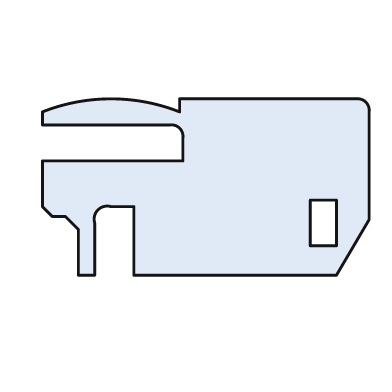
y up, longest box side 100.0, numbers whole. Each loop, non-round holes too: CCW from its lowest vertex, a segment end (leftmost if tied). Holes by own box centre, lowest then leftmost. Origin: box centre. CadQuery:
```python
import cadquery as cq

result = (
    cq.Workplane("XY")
    .moveTo(-39.0, -27.0)
    .lineTo(-34.0, -27.0)
    .lineTo(-34.0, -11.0)
    .threePointArc((-33.0, -7.0), (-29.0, -6.0))
    .lineTo(-22.0, -6.0)
    .lineTo(-22.0, -27.0)
    .lineTo(40.0, -27.0)
    .lineTo(50.0, -10.0)
    .lineTo(50.0, 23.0)
    .threePointArc((49.0, 26.0), (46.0, 27.0))
    .lineTo(-8.0, 27.0)
    .lineTo(-8.0, 23.0)
    .threePointArc((-29.0, 27.0), (-50.0, 23.0))
    .lineTo(-50.0, 19.0)
    .lineTo(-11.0, 19.0)
    .threePointArc((-8.0, 18.0), (-7.0, 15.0))
    .lineTo(-7.0, 8.0)
    .lineTo(-50.0, 8.0)
    .lineTo(-50.0, -6.0)
    .lineTo(-47.0, -9.0)
    .lineTo(-43.0, -9.0)
    .lineTo(-39.0, -13.0)
    .close()
    .moveTo(32.0, -18.0)
    .lineTo(40.0, -18.0)
    .lineTo(40.0, -4.0)
    .lineTo(32.0, -4.0)
    .close()
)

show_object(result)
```